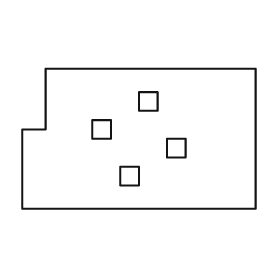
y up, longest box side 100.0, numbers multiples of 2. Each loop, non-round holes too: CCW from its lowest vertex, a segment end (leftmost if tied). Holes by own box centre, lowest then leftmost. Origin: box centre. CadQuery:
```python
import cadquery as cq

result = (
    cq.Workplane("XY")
    .moveTo(-50.0, -30.0)
    .lineTo(50.0, -30.0)
    .lineTo(50.0, 30.0)
    .lineTo(-40.0, 30.0)
    .lineTo(-40.0, 4.0)
    .lineTo(-50.0, 4.0)
    .close()
    .moveTo(-8.0, -20.0)
    .lineTo(0.0, -20.0)
    .lineTo(0.0, -12.0)
    .lineTo(-8.0, -12.0)
    .close()
    .moveTo(12.0, -8.0)
    .lineTo(20.0, -8.0)
    .lineTo(20.0, 0.0)
    .lineTo(12.0, 0.0)
    .close()
    .moveTo(-20.0, 0.0)
    .lineTo(-12.0, 0.0)
    .lineTo(-12.0, 8.0)
    .lineTo(-20.0, 8.0)
    .close()
    .moveTo(0.0, 12.0)
    .lineTo(8.0, 12.0)
    .lineTo(8.0, 20.0)
    .lineTo(0.0, 20.0)
    .close()
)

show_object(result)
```